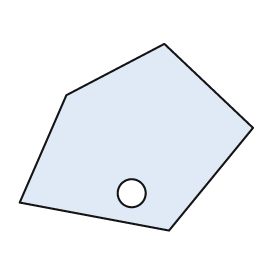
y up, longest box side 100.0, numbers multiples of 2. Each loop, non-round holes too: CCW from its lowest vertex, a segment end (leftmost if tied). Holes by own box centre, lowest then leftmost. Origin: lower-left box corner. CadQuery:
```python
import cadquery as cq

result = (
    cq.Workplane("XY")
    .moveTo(64.0, 0.0)
    .lineTo(100.0, 44.0)
    .lineTo(62.0, 80.0)
    .lineTo(20.0, 58.0)
    .lineTo(0.0, 12.0)
    .close()
    .moveTo(48.0, 16.0)
    .circle(6.0)
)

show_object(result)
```